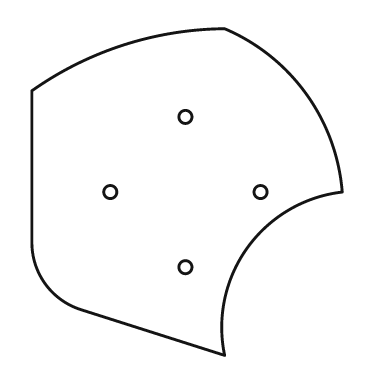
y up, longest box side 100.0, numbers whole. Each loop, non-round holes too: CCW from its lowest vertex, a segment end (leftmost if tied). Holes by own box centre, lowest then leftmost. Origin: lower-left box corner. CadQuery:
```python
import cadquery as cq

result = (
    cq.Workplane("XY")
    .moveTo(59.0, 0.0)
    .threePointArc((66.0, 33.0), (95.0, 50.0))
    .threePointArc((84.0, 80.0), (59.0, 100.0))
    .threePointArc((28.0, 95.0), (0.0, 81.0))
    .lineTo(0.0, 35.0)
    .threePointArc((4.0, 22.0), (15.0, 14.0))
    .close()
    .moveTo(47.0, 27.0)
    .circle(2.0)
    .moveTo(24.0, 50.0)
    .circle(2.0)
    .moveTo(70.0, 50.0)
    .circle(2.0)
    .moveTo(47.0, 73.0)
    .circle(2.0)
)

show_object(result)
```